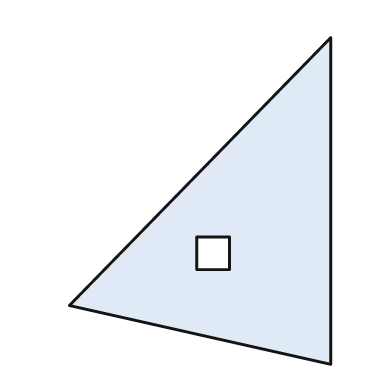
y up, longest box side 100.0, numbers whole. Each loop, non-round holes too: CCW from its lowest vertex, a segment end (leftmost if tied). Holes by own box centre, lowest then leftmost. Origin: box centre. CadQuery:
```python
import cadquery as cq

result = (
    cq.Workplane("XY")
    .moveTo(40.0, -50.0)
    .lineTo(40.0, 50.0)
    .lineTo(-40.0, -32.0)
    .close()
    .moveTo(-1.0, -21.0)
    .lineTo(9.0, -21.0)
    .lineTo(9.0, -11.0)
    .lineTo(-1.0, -11.0)
    .close()
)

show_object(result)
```